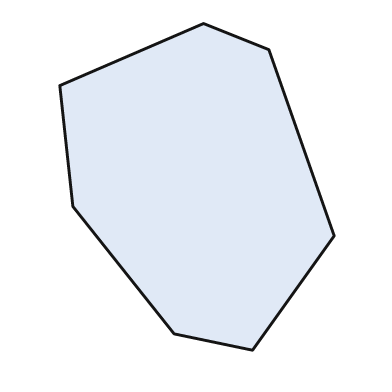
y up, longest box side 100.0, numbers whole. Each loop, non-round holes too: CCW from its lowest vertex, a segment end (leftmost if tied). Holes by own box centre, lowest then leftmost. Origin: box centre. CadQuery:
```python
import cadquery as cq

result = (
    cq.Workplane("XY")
    .moveTo(17.0, -50.0)
    .lineTo(42.0, -15.0)
    .lineTo(22.0, 42.0)
    .lineTo(2.0, 50.0)
    .lineTo(-42.0, 31.0)
    .lineTo(-38.0, -6.0)
    .lineTo(-7.0, -45.0)
    .close()
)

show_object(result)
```